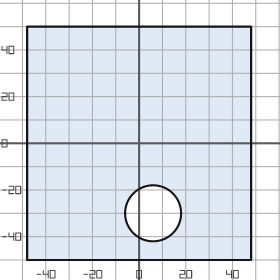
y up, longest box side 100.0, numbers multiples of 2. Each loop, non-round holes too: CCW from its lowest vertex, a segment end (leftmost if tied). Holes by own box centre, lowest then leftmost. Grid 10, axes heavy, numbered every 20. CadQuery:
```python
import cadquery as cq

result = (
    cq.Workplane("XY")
    .moveTo(-48.0, -50.0)
    .lineTo(48.0, -50.0)
    .lineTo(48.0, 50.0)
    .lineTo(-48.0, 50.0)
    .close()
    .moveTo(6.0, -30.0)
    .circle(12.0)
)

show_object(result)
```